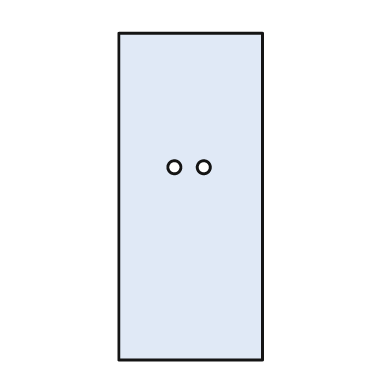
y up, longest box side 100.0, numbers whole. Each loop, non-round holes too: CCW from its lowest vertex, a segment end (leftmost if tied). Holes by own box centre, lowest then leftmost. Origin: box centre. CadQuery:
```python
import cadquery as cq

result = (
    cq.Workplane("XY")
    .moveTo(-22.0, -50.0)
    .lineTo(22.0, -50.0)
    .lineTo(22.0, 50.0)
    .lineTo(-22.0, 50.0)
    .close()
    .moveTo(-5.0, 9.0)
    .circle(2.0)
    .moveTo(4.0, 9.0)
    .circle(2.0)
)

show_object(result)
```